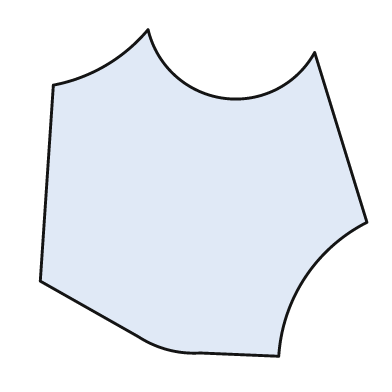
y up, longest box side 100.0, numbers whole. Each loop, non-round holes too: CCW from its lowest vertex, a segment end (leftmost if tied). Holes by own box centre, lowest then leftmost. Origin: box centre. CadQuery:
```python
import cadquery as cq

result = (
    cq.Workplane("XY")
    .moveTo(23.0, -50.0)
    .threePointArc((31.0, -26.0), (50.0, -9.0))
    .lineTo(34.0, 43.0)
    .threePointArc((6.0, 29.0), (-17.0, 50.0))
    .threePointArc((-30.0, 39.0), (-46.0, 33.0))
    .lineTo(-50.0, -27.0)
    .lineTo(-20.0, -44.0)
    .threePointArc((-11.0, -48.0), (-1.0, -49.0))
    .close()
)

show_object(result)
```